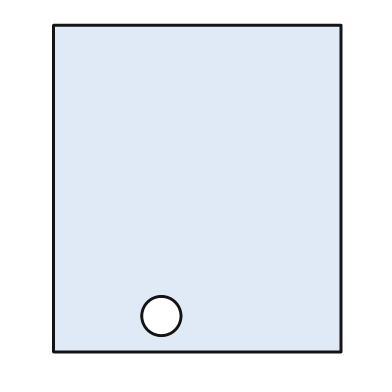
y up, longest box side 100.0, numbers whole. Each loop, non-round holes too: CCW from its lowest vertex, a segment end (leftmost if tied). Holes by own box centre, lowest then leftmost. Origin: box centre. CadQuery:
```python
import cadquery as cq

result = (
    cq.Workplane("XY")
    .moveTo(-44.0, -50.0)
    .lineTo(44.0, -50.0)
    .lineTo(44.0, 50.0)
    .lineTo(-44.0, 50.0)
    .close()
    .moveTo(-11.0, -39.0)
    .circle(6.0)
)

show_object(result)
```